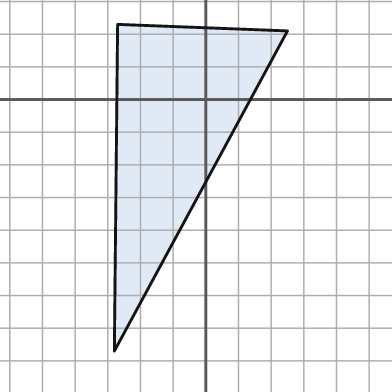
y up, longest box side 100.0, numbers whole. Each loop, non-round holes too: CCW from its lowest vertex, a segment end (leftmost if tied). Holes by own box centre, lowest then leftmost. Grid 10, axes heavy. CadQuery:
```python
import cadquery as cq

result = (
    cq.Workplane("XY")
    .moveTo(-28.0, -77.0)
    .lineTo(25.0, 21.0)
    .lineTo(-27.0, 23.0)
    .close()
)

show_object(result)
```